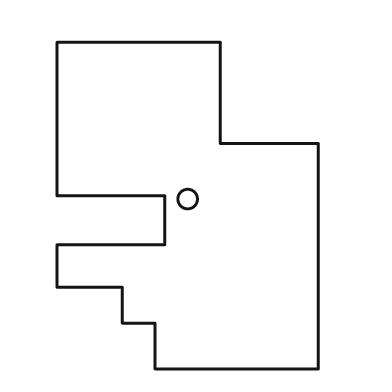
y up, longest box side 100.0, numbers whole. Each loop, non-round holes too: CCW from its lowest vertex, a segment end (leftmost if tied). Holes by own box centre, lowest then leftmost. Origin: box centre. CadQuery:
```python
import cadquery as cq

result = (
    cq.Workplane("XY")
    .moveTo(-10.0, -50.0)
    .lineTo(40.0, -50.0)
    .lineTo(40.0, 19.0)
    .lineTo(10.0, 19.0)
    .lineTo(10.0, 50.0)
    .lineTo(-40.0, 50.0)
    .lineTo(-40.0, 3.0)
    .lineTo(-7.0, 3.0)
    .lineTo(-7.0, -12.0)
    .lineTo(-40.0, -12.0)
    .lineTo(-40.0, -25.0)
    .lineTo(-20.0, -25.0)
    .lineTo(-20.0, -36.0)
    .lineTo(-10.0, -36.0)
    .close()
    .moveTo(0.0, 2.0)
    .circle(3.0)
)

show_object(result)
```